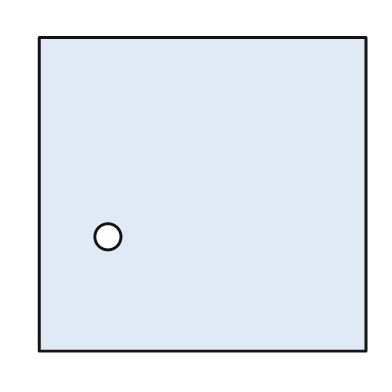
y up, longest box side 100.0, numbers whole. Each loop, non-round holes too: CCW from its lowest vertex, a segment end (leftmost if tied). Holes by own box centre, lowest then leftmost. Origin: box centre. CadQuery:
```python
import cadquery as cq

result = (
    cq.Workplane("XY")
    .moveTo(-50.0, -48.0)
    .lineTo(50.0, -48.0)
    .lineTo(50.0, 48.0)
    .lineTo(-50.0, 48.0)
    .close()
    .moveTo(-29.0, -13.0)
    .circle(4.0)
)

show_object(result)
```